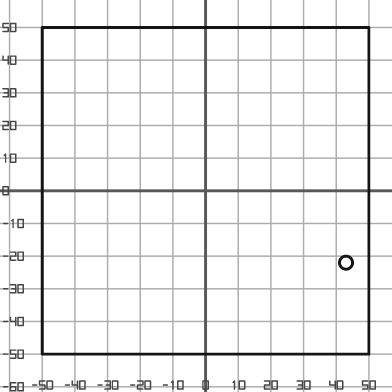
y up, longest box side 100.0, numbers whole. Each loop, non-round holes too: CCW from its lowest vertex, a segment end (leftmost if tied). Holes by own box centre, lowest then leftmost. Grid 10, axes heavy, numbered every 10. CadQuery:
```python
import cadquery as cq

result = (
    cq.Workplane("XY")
    .moveTo(-50.0, -50.0)
    .lineTo(50.0, -50.0)
    .lineTo(50.0, 50.0)
    .lineTo(-50.0, 50.0)
    .close()
    .moveTo(43.0, -22.0)
    .circle(2.0)
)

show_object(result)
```